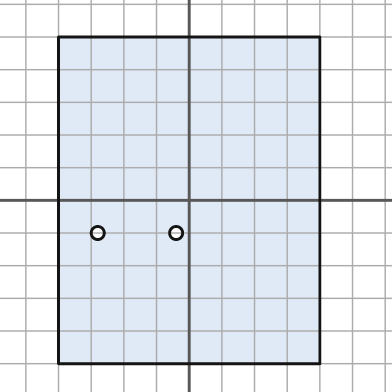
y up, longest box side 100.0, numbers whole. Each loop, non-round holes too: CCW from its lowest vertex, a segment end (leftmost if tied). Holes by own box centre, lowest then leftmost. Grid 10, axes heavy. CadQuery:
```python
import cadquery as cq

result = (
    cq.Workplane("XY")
    .moveTo(-40.0, -50.0)
    .lineTo(40.0, -50.0)
    .lineTo(40.0, 50.0)
    .lineTo(-40.0, 50.0)
    .close()
    .moveTo(-28.0, -10.0)
    .circle(2.0)
    .moveTo(-4.0, -10.0)
    .circle(2.0)
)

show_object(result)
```